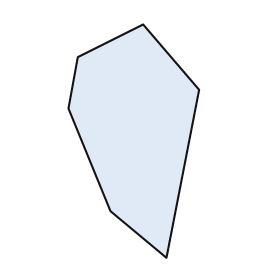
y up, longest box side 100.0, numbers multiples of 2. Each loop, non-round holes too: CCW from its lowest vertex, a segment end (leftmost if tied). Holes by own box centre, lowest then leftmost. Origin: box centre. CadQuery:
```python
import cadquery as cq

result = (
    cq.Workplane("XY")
    .moveTo(14.0, -50.0)
    .lineTo(28.0, 22.0)
    .lineTo(4.0, 50.0)
    .lineTo(-24.0, 36.0)
    .lineTo(-28.0, 14.0)
    .lineTo(-10.0, -30.0)
    .close()
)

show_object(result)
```